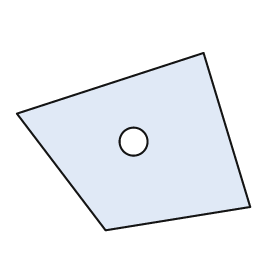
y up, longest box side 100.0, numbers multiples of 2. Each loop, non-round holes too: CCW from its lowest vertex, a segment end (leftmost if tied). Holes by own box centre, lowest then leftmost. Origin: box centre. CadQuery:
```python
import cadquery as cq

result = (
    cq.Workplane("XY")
    .moveTo(-12.0, -38.0)
    .lineTo(50.0, -28.0)
    .lineTo(30.0, 38.0)
    .lineTo(-50.0, 12.0)
    .close()
    .moveTo(0.0, 0.0)
    .circle(6.0)
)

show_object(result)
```